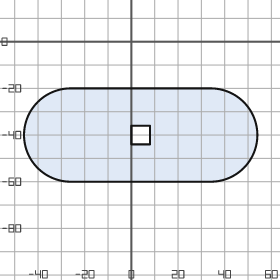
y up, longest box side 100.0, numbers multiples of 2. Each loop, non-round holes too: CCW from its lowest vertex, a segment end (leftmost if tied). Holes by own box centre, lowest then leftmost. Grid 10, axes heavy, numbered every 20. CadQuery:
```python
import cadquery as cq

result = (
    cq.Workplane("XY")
    .moveTo(-26.0, -60.0)
    .lineTo(34.0, -60.0)
    .threePointArc((54.0, -40.0), (34.0, -20.0))
    .lineTo(-26.0, -20.0)
    .threePointArc((-46.0, -40.0), (-26.0, -60.0))
    .close()
    .moveTo(0.0, -44.0)
    .lineTo(8.0, -44.0)
    .lineTo(8.0, -36.0)
    .lineTo(0.0, -36.0)
    .close()
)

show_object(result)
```